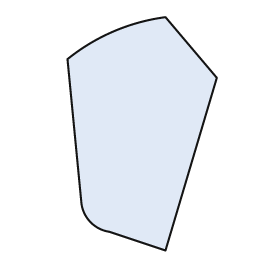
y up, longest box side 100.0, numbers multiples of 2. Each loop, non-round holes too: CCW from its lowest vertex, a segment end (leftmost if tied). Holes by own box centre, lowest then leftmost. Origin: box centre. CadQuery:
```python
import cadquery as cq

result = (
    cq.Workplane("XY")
    .moveTo(10.0, -50.0)
    .lineTo(32.0, 24.0)
    .lineTo(10.0, 50.0)
    .threePointArc((-12.0, 44.0), (-32.0, 32.0))
    .lineTo(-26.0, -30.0)
    .threePointArc((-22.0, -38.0), (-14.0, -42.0))
    .close()
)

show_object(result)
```